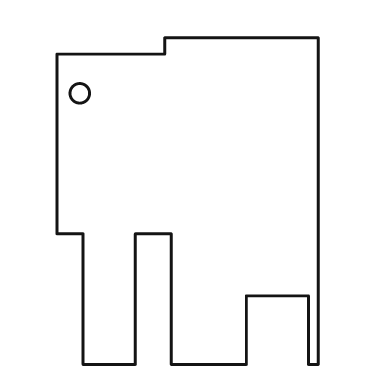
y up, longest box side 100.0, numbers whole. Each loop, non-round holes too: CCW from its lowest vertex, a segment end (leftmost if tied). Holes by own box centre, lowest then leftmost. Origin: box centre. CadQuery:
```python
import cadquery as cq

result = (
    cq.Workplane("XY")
    .moveTo(-32.0, -50.0)
    .lineTo(-16.0, -50.0)
    .lineTo(-16.0, -10.0)
    .lineTo(-5.0, -10.0)
    .lineTo(-5.0, -50.0)
    .lineTo(18.0, -50.0)
    .lineTo(18.0, -29.0)
    .lineTo(37.0, -29.0)
    .lineTo(37.0, -50.0)
    .lineTo(40.0, -50.0)
    .lineTo(40.0, 50.0)
    .lineTo(-7.0, 50.0)
    .lineTo(-7.0, 45.0)
    .lineTo(-40.0, 45.0)
    .lineTo(-40.0, -10.0)
    .lineTo(-32.0, -10.0)
    .close()
    .moveTo(-33.0, 33.0)
    .circle(3.0)
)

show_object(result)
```